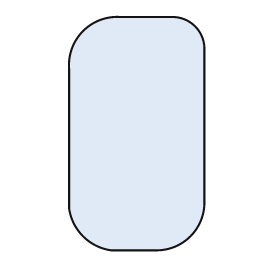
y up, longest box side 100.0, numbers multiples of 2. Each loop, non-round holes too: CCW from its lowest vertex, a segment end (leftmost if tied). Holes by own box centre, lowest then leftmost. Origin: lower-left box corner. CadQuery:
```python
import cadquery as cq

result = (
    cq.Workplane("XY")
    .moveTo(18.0, 0.0)
    .lineTo(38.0, 0.0)
    .threePointArc((52.0, 6.0), (58.0, 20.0))
    .lineTo(58.0, 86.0)
    .threePointArc((54.0, 96.0), (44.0, 100.0))
    .lineTo(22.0, 100.0)
    .threePointArc((6.0, 94.0), (0.0, 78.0))
    .lineTo(0.0, 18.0)
    .threePointArc((6.0, 6.0), (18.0, 0.0))
    .close()
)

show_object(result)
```